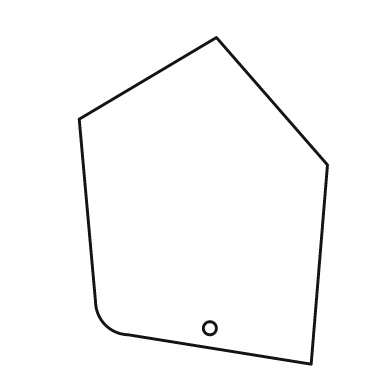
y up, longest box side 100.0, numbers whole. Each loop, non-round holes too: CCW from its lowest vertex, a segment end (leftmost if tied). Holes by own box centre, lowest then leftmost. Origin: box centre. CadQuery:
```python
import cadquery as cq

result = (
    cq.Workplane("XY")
    .moveTo(33.0, -50.0)
    .lineTo(38.0, 11.0)
    .lineTo(4.0, 50.0)
    .lineTo(-38.0, 25.0)
    .lineTo(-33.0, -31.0)
    .threePointArc((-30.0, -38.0), (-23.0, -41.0))
    .close()
    .moveTo(2.0, -39.0)
    .circle(2.0)
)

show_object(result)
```